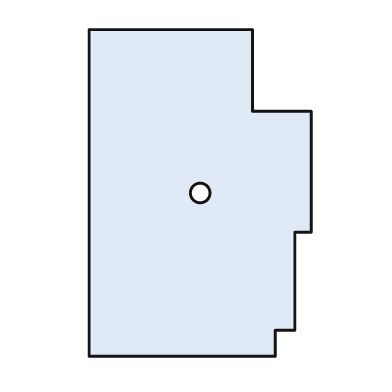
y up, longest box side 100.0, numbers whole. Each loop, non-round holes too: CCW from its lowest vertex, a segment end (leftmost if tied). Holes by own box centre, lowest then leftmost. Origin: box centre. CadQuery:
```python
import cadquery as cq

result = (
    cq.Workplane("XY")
    .moveTo(-34.0, -50.0)
    .lineTo(23.0, -50.0)
    .lineTo(23.0, -42.0)
    .lineTo(29.0, -42.0)
    .lineTo(29.0, -12.0)
    .lineTo(34.0, -12.0)
    .lineTo(34.0, 25.0)
    .lineTo(16.0, 25.0)
    .lineTo(16.0, 50.0)
    .lineTo(-34.0, 50.0)
    .close()
    .moveTo(0.0, 0.0)
    .circle(3.0)
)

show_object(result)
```